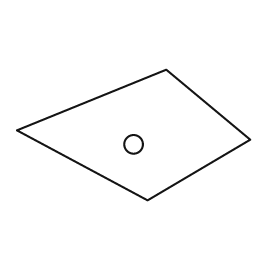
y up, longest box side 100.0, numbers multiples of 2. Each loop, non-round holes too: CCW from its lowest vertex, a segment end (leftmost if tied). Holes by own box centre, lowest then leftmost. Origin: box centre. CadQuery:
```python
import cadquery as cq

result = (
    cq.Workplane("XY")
    .moveTo(6.0, -28.0)
    .lineTo(50.0, -2.0)
    .lineTo(14.0, 28.0)
    .lineTo(-50.0, 2.0)
    .close()
    .moveTo(0.0, -4.0)
    .circle(4.0)
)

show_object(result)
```